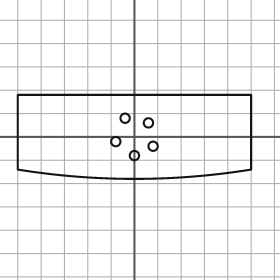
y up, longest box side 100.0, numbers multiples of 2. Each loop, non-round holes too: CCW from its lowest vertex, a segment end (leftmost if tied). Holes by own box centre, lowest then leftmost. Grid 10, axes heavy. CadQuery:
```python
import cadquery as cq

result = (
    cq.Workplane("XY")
    .moveTo(-50.0, -14.0)
    .threePointArc((0.0, -18.0), (50.0, -14.0))
    .lineTo(50.0, 18.0)
    .lineTo(-50.0, 18.0)
    .close()
    .moveTo(0.0, -8.0)
    .circle(2.0)
    .moveTo(8.0, -4.0)
    .circle(2.0)
    .moveTo(-8.0, -2.0)
    .circle(2.0)
    .moveTo(6.0, 6.0)
    .circle(2.0)
    .moveTo(-4.0, 8.0)
    .circle(2.0)
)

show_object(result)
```